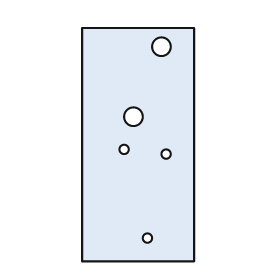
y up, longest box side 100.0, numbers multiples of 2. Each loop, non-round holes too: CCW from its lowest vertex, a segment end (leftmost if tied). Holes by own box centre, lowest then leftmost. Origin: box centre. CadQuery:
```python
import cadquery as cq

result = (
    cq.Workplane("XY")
    .moveTo(-24.0, -50.0)
    .lineTo(24.0, -50.0)
    .lineTo(24.0, 50.0)
    .lineTo(-24.0, 50.0)
    .close()
    .moveTo(4.0, -40.0)
    .circle(2.0)
    .moveTo(12.0, -4.0)
    .circle(2.0)
    .moveTo(-6.0, -2.0)
    .circle(2.0)
    .moveTo(-2.0, 12.0)
    .circle(4.0)
    .moveTo(10.0, 42.0)
    .circle(4.0)
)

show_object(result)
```